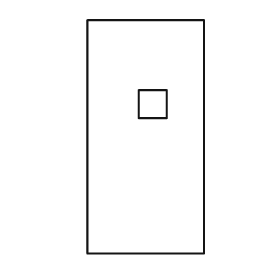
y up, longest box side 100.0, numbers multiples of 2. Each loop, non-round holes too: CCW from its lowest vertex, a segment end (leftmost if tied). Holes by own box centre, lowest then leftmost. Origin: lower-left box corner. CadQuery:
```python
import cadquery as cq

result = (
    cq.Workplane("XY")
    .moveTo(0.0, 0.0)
    .lineTo(50.0, 0.0)
    .lineTo(50.0, 100.0)
    .lineTo(0.0, 100.0)
    .close()
    .moveTo(22.0, 58.0)
    .lineTo(34.0, 58.0)
    .lineTo(34.0, 70.0)
    .lineTo(22.0, 70.0)
    .close()
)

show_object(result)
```